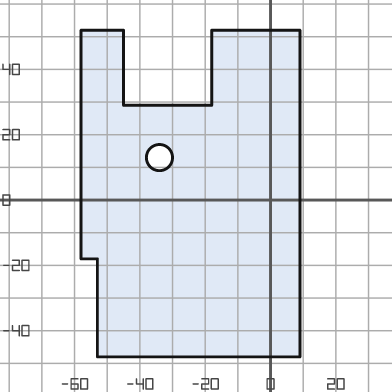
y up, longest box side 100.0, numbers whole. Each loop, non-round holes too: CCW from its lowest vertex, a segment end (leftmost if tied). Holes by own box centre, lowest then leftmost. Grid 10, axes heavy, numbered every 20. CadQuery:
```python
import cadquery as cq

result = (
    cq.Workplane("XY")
    .moveTo(-53.0, -48.0)
    .lineTo(9.0, -48.0)
    .lineTo(9.0, 52.0)
    .lineTo(-18.0, 52.0)
    .lineTo(-18.0, 29.0)
    .lineTo(-45.0, 29.0)
    .lineTo(-45.0, 52.0)
    .lineTo(-58.0, 52.0)
    .lineTo(-58.0, -18.0)
    .lineTo(-53.0, -18.0)
    .close()
    .moveTo(-34.0, 13.0)
    .circle(4.0)
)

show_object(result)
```